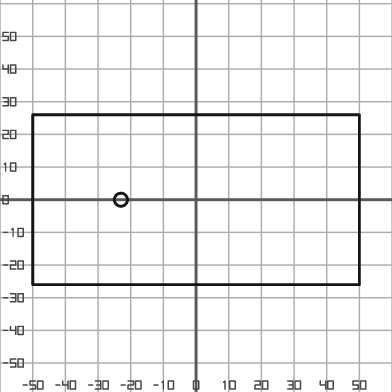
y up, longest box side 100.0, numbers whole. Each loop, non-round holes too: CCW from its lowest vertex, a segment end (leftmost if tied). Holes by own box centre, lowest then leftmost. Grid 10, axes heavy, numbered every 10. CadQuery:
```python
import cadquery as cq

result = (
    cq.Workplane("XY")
    .moveTo(-50.0, -26.0)
    .lineTo(50.0, -26.0)
    .lineTo(50.0, 26.0)
    .lineTo(-50.0, 26.0)
    .close()
    .moveTo(-23.0, 0.0)
    .circle(2.0)
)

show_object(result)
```